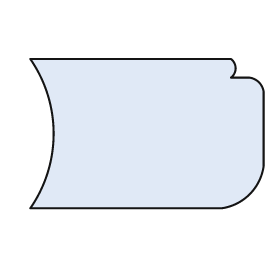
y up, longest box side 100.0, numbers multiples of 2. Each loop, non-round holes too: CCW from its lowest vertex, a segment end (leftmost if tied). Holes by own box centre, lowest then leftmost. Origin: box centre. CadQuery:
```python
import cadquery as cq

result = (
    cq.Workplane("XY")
    .moveTo(-50.0, -32.0)
    .lineTo(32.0, -32.0)
    .threePointArc((44.0, -26.0), (50.0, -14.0))
    .lineTo(50.0, 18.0)
    .threePointArc((48.0, 22.0), (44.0, 24.0))
    .lineTo(36.0, 24.0)
    .threePointArc((38.0, 28.0), (36.0, 32.0))
    .lineTo(-50.0, 32.0)
    .threePointArc((-40.0, 0.0), (-50.0, -32.0))
    .close()
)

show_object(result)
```